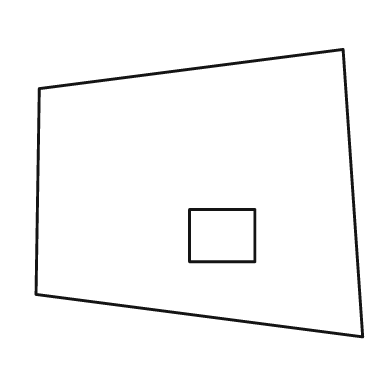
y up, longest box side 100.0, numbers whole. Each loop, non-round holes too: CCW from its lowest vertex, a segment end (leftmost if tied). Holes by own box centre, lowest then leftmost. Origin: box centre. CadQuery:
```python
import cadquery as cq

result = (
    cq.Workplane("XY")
    .moveTo(50.0, -44.0)
    .lineTo(44.0, 44.0)
    .lineTo(-49.0, 32.0)
    .lineTo(-50.0, -31.0)
    .close()
    .moveTo(-3.0, -21.0)
    .lineTo(17.0, -21.0)
    .lineTo(17.0, -5.0)
    .lineTo(-3.0, -5.0)
    .close()
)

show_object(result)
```